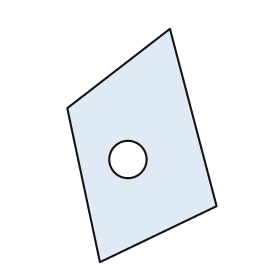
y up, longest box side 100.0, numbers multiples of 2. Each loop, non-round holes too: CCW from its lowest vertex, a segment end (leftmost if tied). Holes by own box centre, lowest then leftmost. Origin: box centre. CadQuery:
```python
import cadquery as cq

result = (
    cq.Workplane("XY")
    .moveTo(-18.0, -50.0)
    .lineTo(32.0, -26.0)
    .lineTo(12.0, 50.0)
    .lineTo(-32.0, 16.0)
    .close()
    .moveTo(-6.0, -6.0)
    .circle(8.0)
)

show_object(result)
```